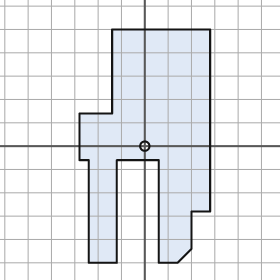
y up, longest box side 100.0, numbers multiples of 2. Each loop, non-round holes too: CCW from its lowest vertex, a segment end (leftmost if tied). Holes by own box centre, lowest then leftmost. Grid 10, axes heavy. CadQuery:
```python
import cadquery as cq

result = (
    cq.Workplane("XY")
    .moveTo(-24.0, -50.0)
    .lineTo(-12.0, -50.0)
    .lineTo(-12.0, -6.0)
    .lineTo(6.0, -6.0)
    .lineTo(6.0, -50.0)
    .lineTo(14.0, -50.0)
    .lineTo(20.0, -44.0)
    .lineTo(20.0, -28.0)
    .lineTo(28.0, -28.0)
    .lineTo(28.0, 50.0)
    .lineTo(-14.0, 50.0)
    .lineTo(-14.0, 14.0)
    .lineTo(-28.0, 14.0)
    .lineTo(-28.0, -6.0)
    .lineTo(-24.0, -6.0)
    .close()
    .moveTo(0.0, 0.0)
    .circle(2.0)
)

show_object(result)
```